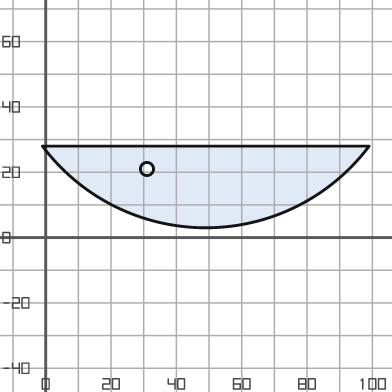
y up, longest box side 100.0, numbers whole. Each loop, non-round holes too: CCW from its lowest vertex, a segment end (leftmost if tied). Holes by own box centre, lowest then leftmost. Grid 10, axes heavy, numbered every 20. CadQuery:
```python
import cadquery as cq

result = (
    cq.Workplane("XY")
    .moveTo(-1.0, 28.0)
    .threePointArc((49.0, 3.0), (99.0, 28.0))
    .close()
    .moveTo(31.0, 21.0)
    .circle(2.0)
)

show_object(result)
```